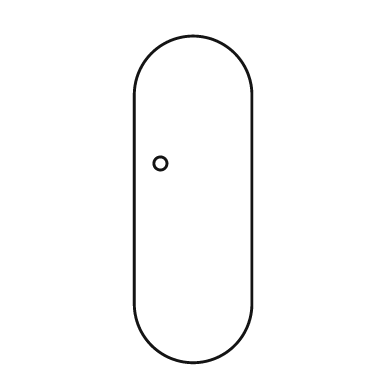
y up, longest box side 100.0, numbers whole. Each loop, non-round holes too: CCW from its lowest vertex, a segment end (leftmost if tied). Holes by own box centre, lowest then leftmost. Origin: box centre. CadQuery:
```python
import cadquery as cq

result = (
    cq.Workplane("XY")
    .moveTo(-18.0, -32.0)
    .threePointArc((0.0, -50.0), (18.0, -32.0))
    .lineTo(18.0, 32.0)
    .threePointArc((0.0, 50.0), (-18.0, 32.0))
    .close()
    .moveTo(-10.0, 11.0)
    .circle(2.0)
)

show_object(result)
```